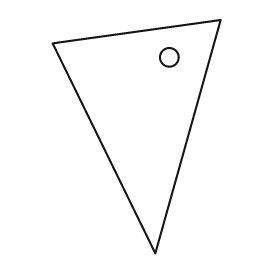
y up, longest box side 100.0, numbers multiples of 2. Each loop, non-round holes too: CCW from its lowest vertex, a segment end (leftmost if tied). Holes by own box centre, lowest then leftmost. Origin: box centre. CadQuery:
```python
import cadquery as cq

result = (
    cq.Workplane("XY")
    .moveTo(8.0, -50.0)
    .lineTo(36.0, 50.0)
    .lineTo(-36.0, 40.0)
    .close()
    .moveTo(14.0, 34.0)
    .circle(4.0)
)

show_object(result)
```